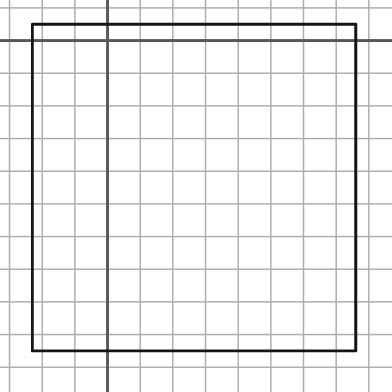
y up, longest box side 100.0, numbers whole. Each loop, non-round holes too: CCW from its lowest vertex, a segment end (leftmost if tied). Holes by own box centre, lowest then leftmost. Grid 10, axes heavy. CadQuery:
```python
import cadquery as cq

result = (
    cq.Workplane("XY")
    .moveTo(-23.0, -95.0)
    .lineTo(76.0, -95.0)
    .lineTo(76.0, 5.0)
    .lineTo(-23.0, 5.0)
    .close()
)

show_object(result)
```